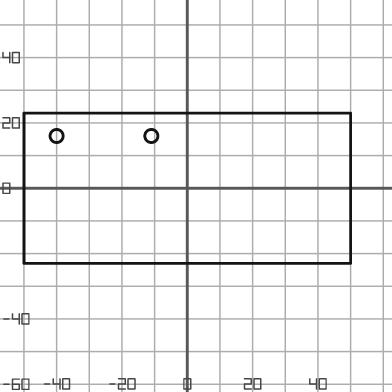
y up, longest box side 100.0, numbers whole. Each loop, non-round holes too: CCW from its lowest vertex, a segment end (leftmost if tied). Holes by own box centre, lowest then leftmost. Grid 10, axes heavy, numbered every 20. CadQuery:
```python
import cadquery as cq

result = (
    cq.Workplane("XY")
    .moveTo(-50.0, -23.0)
    .lineTo(50.0, -23.0)
    .lineTo(50.0, 23.0)
    .lineTo(-50.0, 23.0)
    .close()
    .moveTo(-40.0, 16.0)
    .circle(2.0)
    .moveTo(-11.0, 16.0)
    .circle(2.0)
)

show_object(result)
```